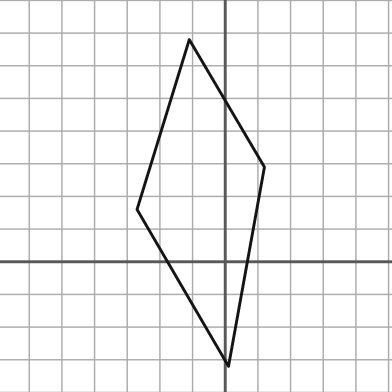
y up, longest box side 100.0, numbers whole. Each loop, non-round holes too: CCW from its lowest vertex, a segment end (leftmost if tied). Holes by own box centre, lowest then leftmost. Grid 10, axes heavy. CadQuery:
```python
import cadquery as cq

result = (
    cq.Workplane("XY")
    .moveTo(1.0, -32.0)
    .lineTo(12.0, 29.0)
    .lineTo(-11.0, 68.0)
    .lineTo(-27.0, 16.0)
    .close()
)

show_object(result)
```